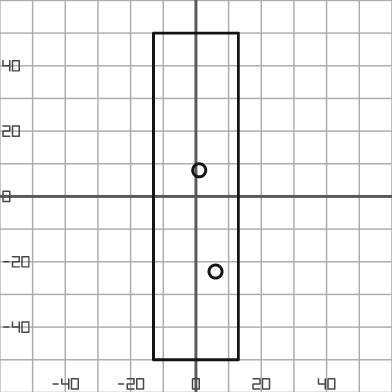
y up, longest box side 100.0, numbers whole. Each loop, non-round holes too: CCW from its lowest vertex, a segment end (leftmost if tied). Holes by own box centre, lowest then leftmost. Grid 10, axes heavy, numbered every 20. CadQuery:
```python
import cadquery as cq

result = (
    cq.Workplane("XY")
    .moveTo(-13.0, -50.0)
    .lineTo(13.0, -50.0)
    .lineTo(13.0, 50.0)
    .lineTo(-13.0, 50.0)
    .close()
    .moveTo(6.0, -23.0)
    .circle(2.0)
    .moveTo(1.0, 8.0)
    .circle(2.0)
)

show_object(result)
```